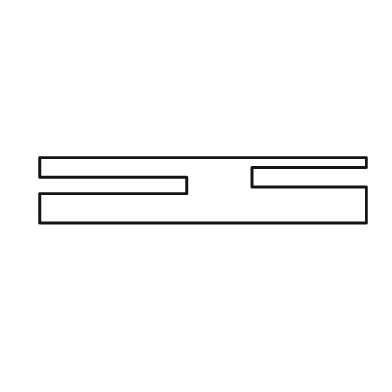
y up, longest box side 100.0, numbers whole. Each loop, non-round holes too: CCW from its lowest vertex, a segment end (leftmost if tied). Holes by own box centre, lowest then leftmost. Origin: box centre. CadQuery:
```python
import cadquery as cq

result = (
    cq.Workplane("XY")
    .moveTo(-50.0, -10.0)
    .lineTo(50.0, -10.0)
    .lineTo(50.0, 1.0)
    .lineTo(15.0, 1.0)
    .lineTo(15.0, 7.0)
    .lineTo(50.0, 7.0)
    .lineTo(50.0, 10.0)
    .lineTo(-50.0, 10.0)
    .lineTo(-50.0, 4.0)
    .lineTo(-5.0, 4.0)
    .lineTo(-5.0, -1.0)
    .lineTo(-50.0, -1.0)
    .close()
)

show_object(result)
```